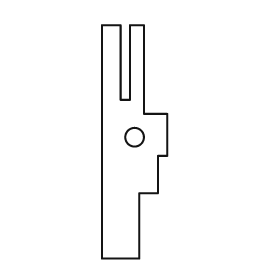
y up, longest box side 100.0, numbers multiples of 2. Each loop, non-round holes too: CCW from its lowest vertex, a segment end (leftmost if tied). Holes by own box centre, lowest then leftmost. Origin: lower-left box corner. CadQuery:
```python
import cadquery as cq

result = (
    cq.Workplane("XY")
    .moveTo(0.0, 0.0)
    .lineTo(16.0, 0.0)
    .lineTo(16.0, 28.0)
    .lineTo(24.0, 28.0)
    .lineTo(24.0, 44.0)
    .lineTo(28.0, 44.0)
    .lineTo(28.0, 62.0)
    .lineTo(18.0, 62.0)
    .lineTo(18.0, 100.0)
    .lineTo(12.0, 100.0)
    .lineTo(12.0, 68.0)
    .lineTo(8.0, 68.0)
    .lineTo(8.0, 100.0)
    .lineTo(0.0, 100.0)
    .close()
    .moveTo(14.0, 52.0)
    .circle(4.0)
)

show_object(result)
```